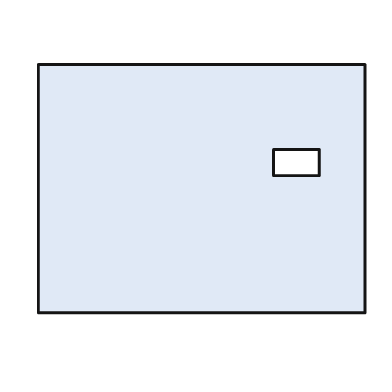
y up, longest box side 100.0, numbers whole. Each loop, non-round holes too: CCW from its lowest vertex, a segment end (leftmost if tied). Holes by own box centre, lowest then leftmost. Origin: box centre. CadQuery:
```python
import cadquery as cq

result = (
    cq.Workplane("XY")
    .moveTo(-50.0, -38.0)
    .lineTo(50.0, -38.0)
    .lineTo(50.0, 38.0)
    .lineTo(-50.0, 38.0)
    .close()
    .moveTo(22.0, 4.0)
    .lineTo(36.0, 4.0)
    .lineTo(36.0, 12.0)
    .lineTo(22.0, 12.0)
    .close()
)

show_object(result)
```